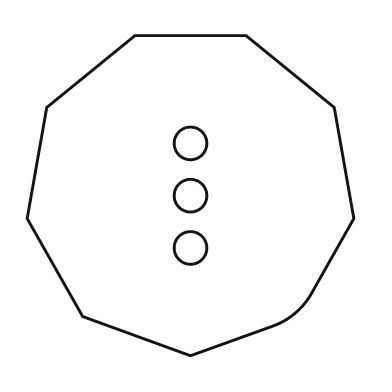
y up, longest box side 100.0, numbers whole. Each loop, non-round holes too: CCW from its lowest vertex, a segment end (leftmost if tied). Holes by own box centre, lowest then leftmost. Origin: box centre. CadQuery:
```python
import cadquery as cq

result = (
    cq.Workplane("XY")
    .moveTo(0.0, -49.0)
    .lineTo(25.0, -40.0)
    .threePointArc((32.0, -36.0), (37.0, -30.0))
    .lineTo(50.0, -7.0)
    .lineTo(44.0, 27.0)
    .lineTo(17.0, 49.0)
    .lineTo(-17.0, 49.0)
    .lineTo(-44.0, 27.0)
    .lineTo(-50.0, -7.0)
    .lineTo(-33.0, -37.0)
    .close()
    .moveTo(0.0, -16.0)
    .circle(5.0)
    .moveTo(0.0, 0.0)
    .circle(5.0)
    .moveTo(0.0, 16.0)
    .circle(5.0)
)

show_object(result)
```